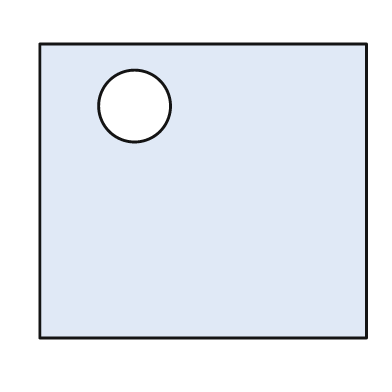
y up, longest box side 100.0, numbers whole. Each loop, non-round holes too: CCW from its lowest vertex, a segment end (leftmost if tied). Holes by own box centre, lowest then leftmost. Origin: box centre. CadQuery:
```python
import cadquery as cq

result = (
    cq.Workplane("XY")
    .moveTo(-50.0, -45.0)
    .lineTo(50.0, -45.0)
    .lineTo(50.0, 45.0)
    .lineTo(-50.0, 45.0)
    .close()
    .moveTo(-21.0, 26.0)
    .circle(11.0)
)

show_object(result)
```